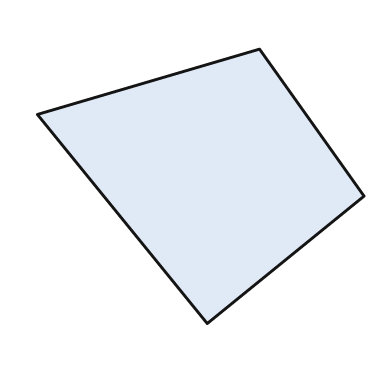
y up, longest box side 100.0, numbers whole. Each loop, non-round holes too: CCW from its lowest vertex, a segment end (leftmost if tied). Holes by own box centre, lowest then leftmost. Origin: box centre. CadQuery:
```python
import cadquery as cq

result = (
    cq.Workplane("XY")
    .moveTo(2.0, -42.0)
    .lineTo(50.0, -3.0)
    .lineTo(18.0, 42.0)
    .lineTo(-50.0, 22.0)
    .close()
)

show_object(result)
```